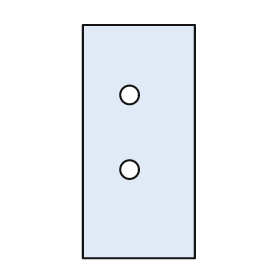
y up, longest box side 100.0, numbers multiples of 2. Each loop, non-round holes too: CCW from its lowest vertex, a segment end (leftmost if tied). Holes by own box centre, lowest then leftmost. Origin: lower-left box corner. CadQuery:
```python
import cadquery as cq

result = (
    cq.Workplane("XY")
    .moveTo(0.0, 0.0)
    .lineTo(48.0, 0.0)
    .lineTo(48.0, 100.0)
    .lineTo(0.0, 100.0)
    .close()
    .moveTo(20.0, 38.0)
    .circle(4.0)
    .moveTo(20.0, 70.0)
    .circle(4.0)
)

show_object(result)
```